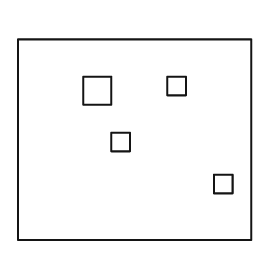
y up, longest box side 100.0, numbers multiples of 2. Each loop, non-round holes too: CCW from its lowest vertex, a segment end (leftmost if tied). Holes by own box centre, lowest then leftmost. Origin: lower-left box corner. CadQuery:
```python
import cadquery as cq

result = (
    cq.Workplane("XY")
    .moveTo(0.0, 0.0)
    .lineTo(100.0, 0.0)
    .lineTo(100.0, 86.0)
    .lineTo(0.0, 86.0)
    .close()
    .moveTo(84.0, 20.0)
    .lineTo(92.0, 20.0)
    .lineTo(92.0, 28.0)
    .lineTo(84.0, 28.0)
    .close()
    .moveTo(40.0, 38.0)
    .lineTo(48.0, 38.0)
    .lineTo(48.0, 46.0)
    .lineTo(40.0, 46.0)
    .close()
    .moveTo(28.0, 58.0)
    .lineTo(40.0, 58.0)
    .lineTo(40.0, 70.0)
    .lineTo(28.0, 70.0)
    .close()
    .moveTo(64.0, 62.0)
    .lineTo(72.0, 62.0)
    .lineTo(72.0, 70.0)
    .lineTo(64.0, 70.0)
    .close()
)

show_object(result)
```